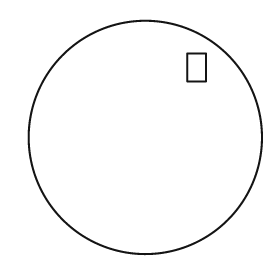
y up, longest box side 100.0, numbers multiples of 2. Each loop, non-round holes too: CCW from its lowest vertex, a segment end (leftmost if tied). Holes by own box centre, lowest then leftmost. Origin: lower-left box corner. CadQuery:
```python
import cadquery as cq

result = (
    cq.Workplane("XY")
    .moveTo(50.0, 50.0)
    .circle(50.0)
    .moveTo(68.0, 74.0)
    .lineTo(76.0, 74.0)
    .lineTo(76.0, 86.0)
    .lineTo(68.0, 86.0)
    .close()
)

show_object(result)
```